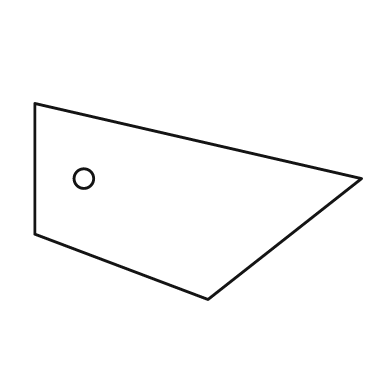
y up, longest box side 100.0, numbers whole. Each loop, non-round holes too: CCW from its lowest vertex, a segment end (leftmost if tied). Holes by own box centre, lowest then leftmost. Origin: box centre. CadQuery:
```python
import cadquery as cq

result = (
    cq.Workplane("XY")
    .moveTo(3.0, -30.0)
    .lineTo(50.0, 7.0)
    .lineTo(-50.0, 30.0)
    .lineTo(-50.0, -10.0)
    .close()
    .moveTo(-35.0, 7.0)
    .circle(3.0)
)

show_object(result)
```